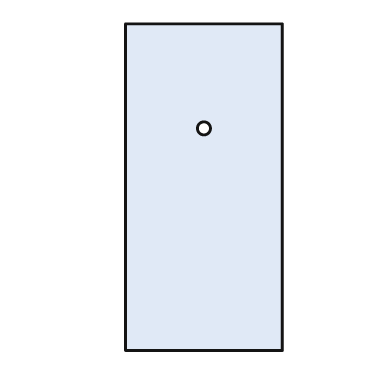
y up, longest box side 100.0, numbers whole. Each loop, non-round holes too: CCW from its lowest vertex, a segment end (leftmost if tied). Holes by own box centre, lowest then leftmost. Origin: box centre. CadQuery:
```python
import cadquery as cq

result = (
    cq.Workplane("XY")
    .moveTo(-24.0, -50.0)
    .lineTo(24.0, -50.0)
    .lineTo(24.0, 50.0)
    .lineTo(-24.0, 50.0)
    .close()
    .moveTo(0.0, 18.0)
    .circle(2.0)
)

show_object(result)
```